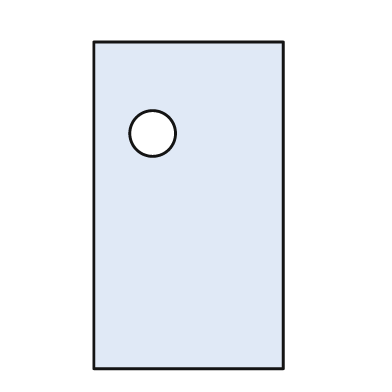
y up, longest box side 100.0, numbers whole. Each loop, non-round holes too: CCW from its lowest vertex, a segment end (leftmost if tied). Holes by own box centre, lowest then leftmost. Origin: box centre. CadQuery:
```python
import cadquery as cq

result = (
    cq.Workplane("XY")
    .moveTo(-29.0, -50.0)
    .lineTo(29.0, -50.0)
    .lineTo(29.0, 50.0)
    .lineTo(-29.0, 50.0)
    .close()
    .moveTo(-11.0, 22.0)
    .circle(7.0)
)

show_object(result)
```